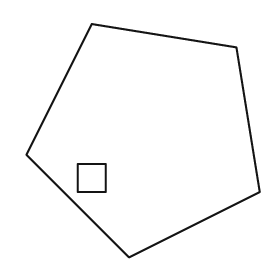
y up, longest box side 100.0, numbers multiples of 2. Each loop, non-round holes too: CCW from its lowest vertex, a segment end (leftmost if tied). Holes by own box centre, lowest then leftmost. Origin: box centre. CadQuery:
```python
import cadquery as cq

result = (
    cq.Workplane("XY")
    .moveTo(-6.0, -50.0)
    .lineTo(50.0, -22.0)
    .lineTo(40.0, 40.0)
    .lineTo(-22.0, 50.0)
    .lineTo(-50.0, -6.0)
    .close()
    .moveTo(-28.0, -22.0)
    .lineTo(-16.0, -22.0)
    .lineTo(-16.0, -10.0)
    .lineTo(-28.0, -10.0)
    .close()
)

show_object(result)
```